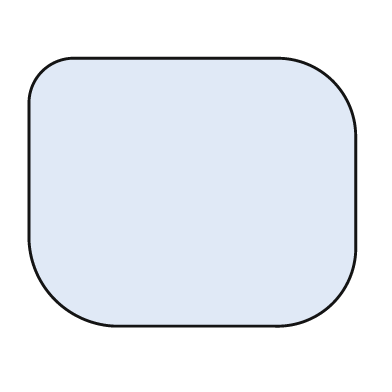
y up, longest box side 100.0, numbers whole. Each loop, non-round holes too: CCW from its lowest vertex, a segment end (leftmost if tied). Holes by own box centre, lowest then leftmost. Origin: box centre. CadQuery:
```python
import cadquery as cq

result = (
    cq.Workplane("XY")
    .moveTo(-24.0, -41.0)
    .lineTo(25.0, -41.0)
    .threePointArc((43.0, -34.0), (50.0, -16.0))
    .lineTo(50.0, 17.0)
    .threePointArc((43.0, 34.0), (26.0, 41.0))
    .lineTo(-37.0, 41.0)
    .threePointArc((-46.0, 37.0), (-50.0, 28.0))
    .lineTo(-50.0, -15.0)
    .threePointArc((-42.0, -33.0), (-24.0, -41.0))
    .close()
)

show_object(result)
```